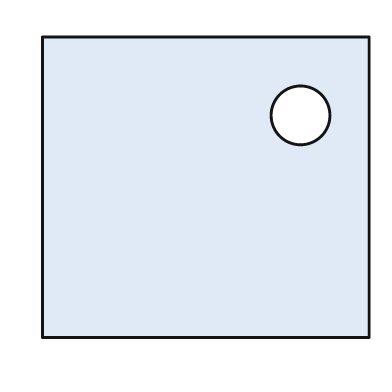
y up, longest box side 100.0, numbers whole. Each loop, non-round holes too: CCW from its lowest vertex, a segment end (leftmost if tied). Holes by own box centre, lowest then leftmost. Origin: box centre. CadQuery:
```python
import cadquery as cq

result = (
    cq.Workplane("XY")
    .moveTo(-50.0, -46.0)
    .lineTo(50.0, -46.0)
    .lineTo(50.0, 46.0)
    .lineTo(-50.0, 46.0)
    .close()
    .moveTo(29.0, 22.0)
    .circle(9.0)
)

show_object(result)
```